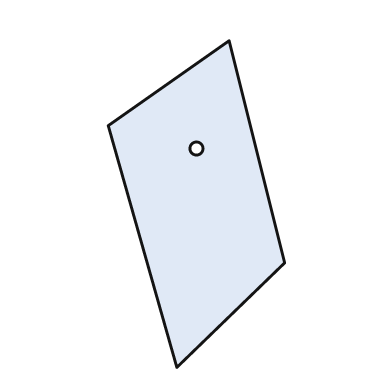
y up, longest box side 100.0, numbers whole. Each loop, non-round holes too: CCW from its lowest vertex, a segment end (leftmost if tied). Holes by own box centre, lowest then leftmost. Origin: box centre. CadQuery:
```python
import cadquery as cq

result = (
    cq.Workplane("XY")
    .moveTo(-6.0, -50.0)
    .lineTo(27.0, -18.0)
    .lineTo(10.0, 50.0)
    .lineTo(-27.0, 24.0)
    .close()
    .moveTo(0.0, 17.0)
    .circle(2.0)
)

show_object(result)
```